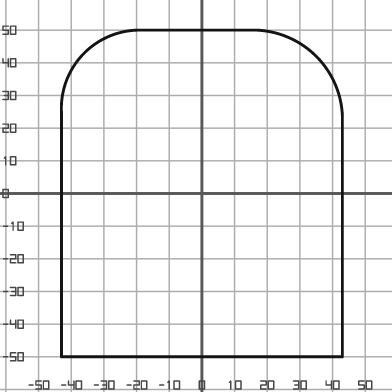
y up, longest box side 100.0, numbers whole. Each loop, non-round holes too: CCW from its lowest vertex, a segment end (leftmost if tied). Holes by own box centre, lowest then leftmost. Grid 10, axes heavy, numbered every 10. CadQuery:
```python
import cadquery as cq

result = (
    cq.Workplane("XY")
    .moveTo(-43.0, -50.0)
    .lineTo(43.0, -50.0)
    .lineTo(43.0, 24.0)
    .threePointArc((35.0, 42.0), (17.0, 50.0))
    .lineTo(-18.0, 50.0)
    .threePointArc((-36.0, 43.0), (-43.0, 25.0))
    .close()
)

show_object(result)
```